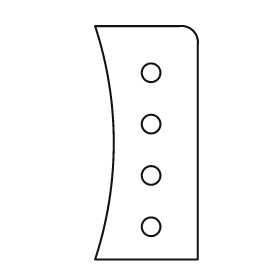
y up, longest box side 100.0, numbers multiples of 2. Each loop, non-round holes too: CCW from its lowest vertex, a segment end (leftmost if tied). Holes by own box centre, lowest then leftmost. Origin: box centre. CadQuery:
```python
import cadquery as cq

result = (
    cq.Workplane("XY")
    .moveTo(-22.0, -50.0)
    .lineTo(22.0, -50.0)
    .lineTo(22.0, 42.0)
    .threePointArc((20.0, 48.0), (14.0, 50.0))
    .lineTo(-22.0, 50.0)
    .threePointArc((-14.0, 0.0), (-22.0, -50.0))
    .close()
    .moveTo(2.0, -36.0)
    .circle(4.0)
    .moveTo(2.0, -14.0)
    .circle(4.0)
    .moveTo(2.0, 8.0)
    .circle(4.0)
    .moveTo(2.0, 30.0)
    .circle(4.0)
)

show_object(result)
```